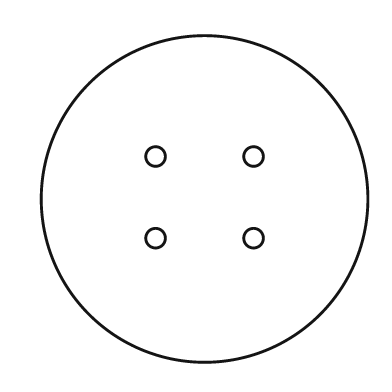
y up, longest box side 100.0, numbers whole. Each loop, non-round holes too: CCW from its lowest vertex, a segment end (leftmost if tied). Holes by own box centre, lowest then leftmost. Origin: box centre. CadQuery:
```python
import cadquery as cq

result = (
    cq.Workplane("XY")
    .moveTo(0.0, 0.0)
    .circle(50.0)
    .moveTo(-15.0, -12.0)
    .circle(3.0)
    .moveTo(15.0, -12.0)
    .circle(3.0)
    .moveTo(-15.0, 13.0)
    .circle(3.0)
    .moveTo(15.0, 13.0)
    .circle(3.0)
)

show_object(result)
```